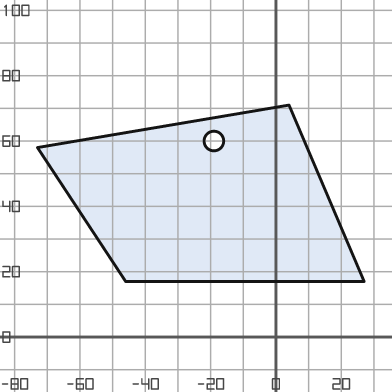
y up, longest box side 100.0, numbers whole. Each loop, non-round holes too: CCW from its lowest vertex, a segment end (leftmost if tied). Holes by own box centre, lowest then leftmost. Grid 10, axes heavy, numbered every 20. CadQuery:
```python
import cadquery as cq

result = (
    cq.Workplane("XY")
    .moveTo(-46.0, 17.0)
    .lineTo(27.0, 17.0)
    .lineTo(4.0, 71.0)
    .lineTo(-73.0, 58.0)
    .close()
    .moveTo(-19.0, 60.0)
    .circle(3.0)
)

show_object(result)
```